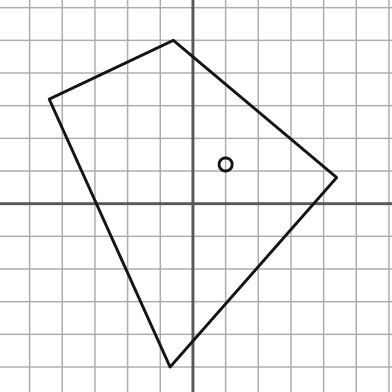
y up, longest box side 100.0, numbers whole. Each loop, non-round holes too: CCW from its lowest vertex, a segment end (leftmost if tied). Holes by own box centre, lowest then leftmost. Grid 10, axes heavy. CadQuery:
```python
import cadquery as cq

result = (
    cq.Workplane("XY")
    .moveTo(-7.0, -50.0)
    .lineTo(44.0, 8.0)
    .lineTo(-6.0, 50.0)
    .lineTo(-44.0, 32.0)
    .close()
    .moveTo(10.0, 12.0)
    .circle(2.0)
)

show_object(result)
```